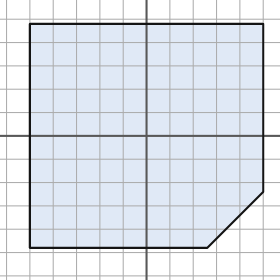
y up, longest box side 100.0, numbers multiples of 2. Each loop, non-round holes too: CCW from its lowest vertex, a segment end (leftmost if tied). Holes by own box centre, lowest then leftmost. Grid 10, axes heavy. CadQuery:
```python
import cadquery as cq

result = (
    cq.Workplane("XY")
    .moveTo(-50.0, -48.0)
    .lineTo(26.0, -48.0)
    .lineTo(50.0, -24.0)
    .lineTo(50.0, 48.0)
    .lineTo(-50.0, 48.0)
    .close()
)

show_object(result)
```